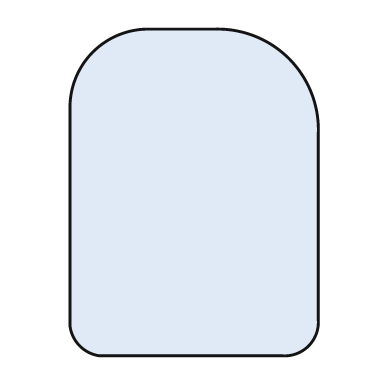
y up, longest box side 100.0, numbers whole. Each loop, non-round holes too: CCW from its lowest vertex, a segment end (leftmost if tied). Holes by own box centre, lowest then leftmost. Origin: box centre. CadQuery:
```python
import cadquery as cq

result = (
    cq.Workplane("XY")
    .moveTo(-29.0, -50.0)
    .lineTo(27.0, -50.0)
    .threePointArc((35.0, -47.0), (38.0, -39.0))
    .lineTo(38.0, 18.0)
    .threePointArc((29.0, 41.0), (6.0, 50.0))
    .lineTo(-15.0, 50.0)
    .threePointArc((-31.0, 43.0), (-38.0, 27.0))
    .lineTo(-38.0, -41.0)
    .threePointArc((-35.0, -47.0), (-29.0, -50.0))
    .close()
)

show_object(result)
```